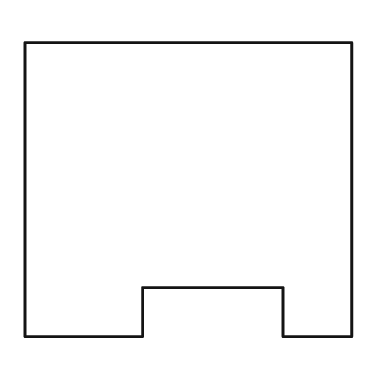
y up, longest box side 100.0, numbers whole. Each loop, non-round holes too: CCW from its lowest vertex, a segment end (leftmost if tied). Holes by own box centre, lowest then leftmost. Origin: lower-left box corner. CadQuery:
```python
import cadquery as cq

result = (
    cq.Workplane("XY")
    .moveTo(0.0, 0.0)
    .lineTo(36.0, 0.0)
    .lineTo(36.0, 15.0)
    .lineTo(79.0, 15.0)
    .lineTo(79.0, 0.0)
    .lineTo(100.0, 0.0)
    .lineTo(100.0, 90.0)
    .lineTo(0.0, 90.0)
    .close()
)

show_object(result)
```